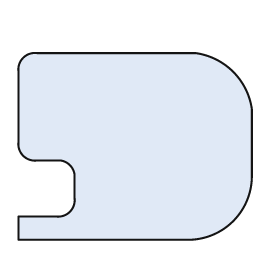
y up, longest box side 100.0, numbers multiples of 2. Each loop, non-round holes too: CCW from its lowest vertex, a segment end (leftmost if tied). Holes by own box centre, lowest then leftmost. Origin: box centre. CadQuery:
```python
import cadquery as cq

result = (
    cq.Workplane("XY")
    .moveTo(-50.0, -40.0)
    .lineTo(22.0, -40.0)
    .threePointArc((42.0, -32.0), (50.0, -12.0))
    .lineTo(50.0, 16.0)
    .threePointArc((42.0, 32.0), (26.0, 40.0))
    .lineTo(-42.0, 40.0)
    .threePointArc((-48.0, 38.0), (-50.0, 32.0))
    .lineTo(-50.0, 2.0)
    .threePointArc((-48.0, -4.0), (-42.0, -6.0))
    .lineTo(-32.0, -6.0)
    .threePointArc((-28.0, -8.0), (-26.0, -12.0))
    .lineTo(-26.0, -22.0)
    .threePointArc((-28.0, -28.0), (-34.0, -30.0))
    .lineTo(-50.0, -30.0)
    .close()
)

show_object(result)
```